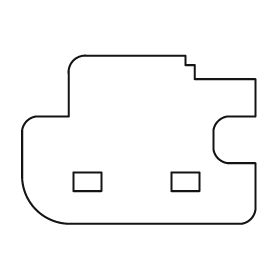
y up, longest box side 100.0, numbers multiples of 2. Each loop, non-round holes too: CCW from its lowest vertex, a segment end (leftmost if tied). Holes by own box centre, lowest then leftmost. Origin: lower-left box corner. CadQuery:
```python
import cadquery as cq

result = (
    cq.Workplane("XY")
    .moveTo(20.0, 0.0)
    .lineTo(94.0, 0.0)
    .threePointArc((98.0, 2.0), (100.0, 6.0))
    .lineTo(100.0, 26.0)
    .lineTo(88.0, 26.0)
    .threePointArc((84.0, 28.0), (82.0, 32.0))
    .lineTo(82.0, 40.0)
    .threePointArc((84.0, 44.0), (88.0, 46.0))
    .lineTo(100.0, 46.0)
    .lineTo(100.0, 62.0)
    .lineTo(74.0, 62.0)
    .lineTo(74.0, 68.0)
    .lineTo(70.0, 68.0)
    .lineTo(70.0, 72.0)
    .lineTo(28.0, 72.0)
    .threePointArc((22.0, 70.0), (20.0, 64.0))
    .lineTo(20.0, 46.0)
    .lineTo(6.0, 46.0)
    .threePointArc((2.0, 44.0), (0.0, 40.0))
    .lineTo(0.0, 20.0)
    .threePointArc((6.0, 6.0), (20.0, 0.0))
    .close()
    .moveTo(22.0, 14.0)
    .lineTo(34.0, 14.0)
    .lineTo(34.0, 22.0)
    .lineTo(22.0, 22.0)
    .close()
    .moveTo(64.0, 14.0)
    .lineTo(76.0, 14.0)
    .lineTo(76.0, 22.0)
    .lineTo(64.0, 22.0)
    .close()
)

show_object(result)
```